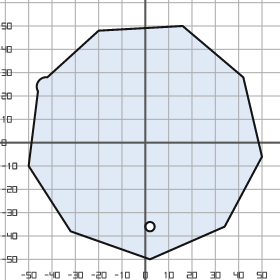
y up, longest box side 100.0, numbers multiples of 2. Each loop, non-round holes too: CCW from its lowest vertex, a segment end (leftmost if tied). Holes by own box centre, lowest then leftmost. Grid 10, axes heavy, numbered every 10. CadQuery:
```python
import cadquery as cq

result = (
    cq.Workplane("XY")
    .moveTo(2.0, -50.0)
    .lineTo(34.0, -36.0)
    .lineTo(50.0, -6.0)
    .lineTo(42.0, 28.0)
    .lineTo(16.0, 50.0)
    .lineTo(-20.0, 48.0)
    .lineTo(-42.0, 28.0)
    .threePointArc((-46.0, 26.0), (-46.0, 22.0))
    .lineTo(-50.0, -10.0)
    .lineTo(-32.0, -38.0)
    .close()
    .moveTo(2.0, -36.0)
    .circle(2.0)
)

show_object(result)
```